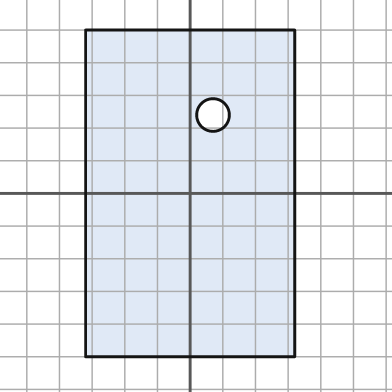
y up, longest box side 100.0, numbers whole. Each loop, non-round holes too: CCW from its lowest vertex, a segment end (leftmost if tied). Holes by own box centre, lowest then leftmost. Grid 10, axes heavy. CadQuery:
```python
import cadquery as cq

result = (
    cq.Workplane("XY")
    .moveTo(-32.0, -50.0)
    .lineTo(32.0, -50.0)
    .lineTo(32.0, 50.0)
    .lineTo(-32.0, 50.0)
    .close()
    .moveTo(7.0, 24.0)
    .circle(5.0)
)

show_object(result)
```